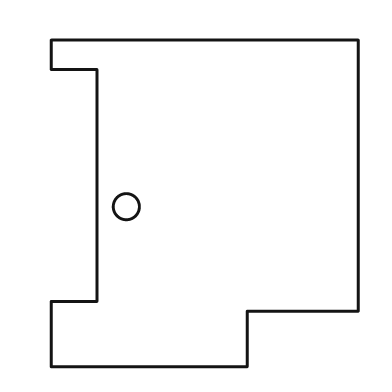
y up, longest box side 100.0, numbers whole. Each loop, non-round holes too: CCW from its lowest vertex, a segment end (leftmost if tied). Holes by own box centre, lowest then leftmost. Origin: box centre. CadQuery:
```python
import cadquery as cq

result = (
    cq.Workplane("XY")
    .moveTo(-47.0, -50.0)
    .lineTo(13.0, -50.0)
    .lineTo(13.0, -33.0)
    .lineTo(47.0, -33.0)
    .lineTo(47.0, 50.0)
    .lineTo(-47.0, 50.0)
    .lineTo(-47.0, 41.0)
    .lineTo(-33.0, 41.0)
    .lineTo(-33.0, -30.0)
    .lineTo(-47.0, -30.0)
    .close()
    .moveTo(-24.0, -1.0)
    .circle(4.0)
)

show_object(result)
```